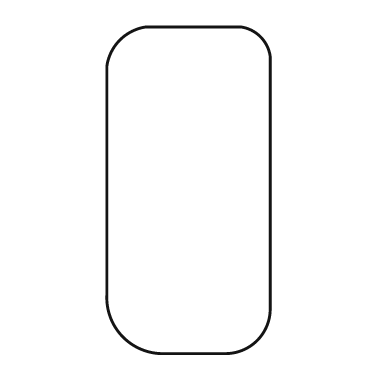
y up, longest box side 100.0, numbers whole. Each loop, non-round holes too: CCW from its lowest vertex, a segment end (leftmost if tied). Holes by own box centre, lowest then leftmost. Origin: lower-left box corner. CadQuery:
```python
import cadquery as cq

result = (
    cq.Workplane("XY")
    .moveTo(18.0, 0.0)
    .lineTo(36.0, 0.0)
    .threePointArc((46.0, 4.0), (50.0, 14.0))
    .lineTo(50.0, 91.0)
    .threePointArc((47.0, 97.0), (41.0, 100.0))
    .lineTo(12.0, 100.0)
    .threePointArc((4.0, 96.0), (0.0, 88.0))
    .lineTo(0.0, 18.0)
    .threePointArc((5.0, 5.0), (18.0, 0.0))
    .close()
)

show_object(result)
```